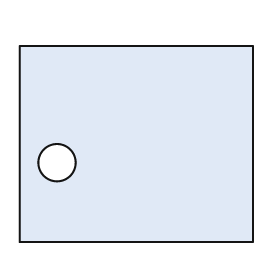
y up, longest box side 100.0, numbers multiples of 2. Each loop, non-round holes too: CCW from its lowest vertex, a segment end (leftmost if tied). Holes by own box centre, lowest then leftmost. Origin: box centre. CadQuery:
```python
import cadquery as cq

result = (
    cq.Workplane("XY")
    .moveTo(-50.0, -42.0)
    .lineTo(50.0, -42.0)
    .lineTo(50.0, 42.0)
    .lineTo(-50.0, 42.0)
    .close()
    .moveTo(-34.0, -8.0)
    .circle(8.0)
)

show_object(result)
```